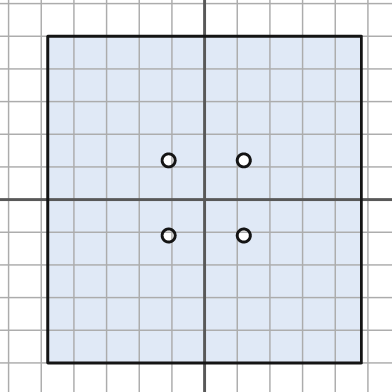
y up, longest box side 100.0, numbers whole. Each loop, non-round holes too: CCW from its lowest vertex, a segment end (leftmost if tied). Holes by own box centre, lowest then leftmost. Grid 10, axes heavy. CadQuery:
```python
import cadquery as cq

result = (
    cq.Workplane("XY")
    .moveTo(-48.0, -50.0)
    .lineTo(48.0, -50.0)
    .lineTo(48.0, 50.0)
    .lineTo(-48.0, 50.0)
    .close()
    .moveTo(-11.0, -11.0)
    .circle(2.0)
    .moveTo(12.0, -11.0)
    .circle(2.0)
    .moveTo(-11.0, 12.0)
    .circle(2.0)
    .moveTo(12.0, 12.0)
    .circle(2.0)
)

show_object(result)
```